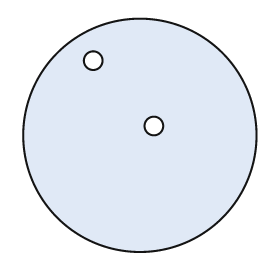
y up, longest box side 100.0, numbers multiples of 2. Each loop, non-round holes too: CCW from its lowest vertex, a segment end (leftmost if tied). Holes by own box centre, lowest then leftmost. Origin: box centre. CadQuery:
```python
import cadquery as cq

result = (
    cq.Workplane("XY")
    .moveTo(0.0, 0.0)
    .circle(50.0)
    .moveTo(6.0, 4.0)
    .circle(4.0)
    .moveTo(-20.0, 32.0)
    .circle(4.0)
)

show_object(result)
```